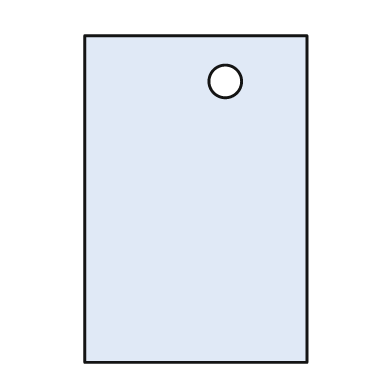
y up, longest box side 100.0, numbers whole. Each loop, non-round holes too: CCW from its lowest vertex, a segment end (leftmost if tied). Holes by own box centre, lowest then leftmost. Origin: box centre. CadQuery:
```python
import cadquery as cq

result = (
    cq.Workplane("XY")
    .moveTo(-34.0, -50.0)
    .lineTo(34.0, -50.0)
    .lineTo(34.0, 50.0)
    .lineTo(-34.0, 50.0)
    .close()
    .moveTo(9.0, 36.0)
    .circle(5.0)
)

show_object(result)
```